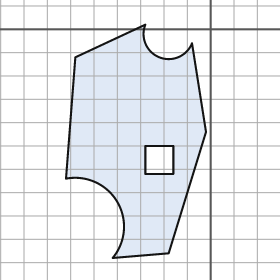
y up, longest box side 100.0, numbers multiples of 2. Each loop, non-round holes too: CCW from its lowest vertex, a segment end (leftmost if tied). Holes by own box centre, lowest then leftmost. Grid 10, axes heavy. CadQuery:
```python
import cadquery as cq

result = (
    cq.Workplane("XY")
    .moveTo(-42.0, -98.0)
    .lineTo(-18.0, -96.0)
    .lineTo(-2.0, -44.0)
    .lineTo(-8.0, -6.0)
    .threePointArc((-22.0, -12.0), (-28.0, 2.0))
    .lineTo(-58.0, -12.0)
    .lineTo(-62.0, -64.0)
    .threePointArc((-40.0, -74.0), (-42.0, -98.0))
    .close()
    .moveTo(-28.0, -62.0)
    .lineTo(-16.0, -62.0)
    .lineTo(-16.0, -50.0)
    .lineTo(-28.0, -50.0)
    .close()
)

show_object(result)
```